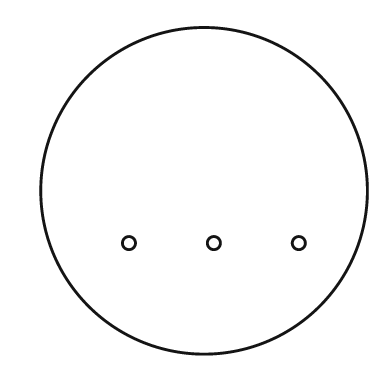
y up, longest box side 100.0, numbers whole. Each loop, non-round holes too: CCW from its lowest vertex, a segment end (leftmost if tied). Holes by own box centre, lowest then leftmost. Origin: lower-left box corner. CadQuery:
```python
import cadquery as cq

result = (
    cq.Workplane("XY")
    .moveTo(50.0, 50.0)
    .circle(50.0)
    .moveTo(27.0, 34.0)
    .circle(2.0)
    .moveTo(53.0, 34.0)
    .circle(2.0)
    .moveTo(79.0, 34.0)
    .circle(2.0)
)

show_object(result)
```